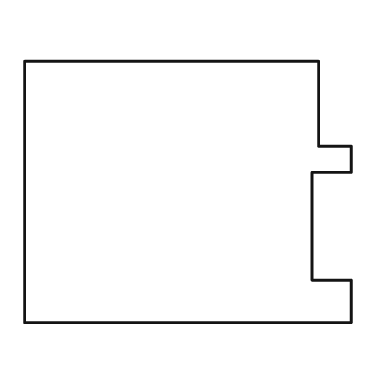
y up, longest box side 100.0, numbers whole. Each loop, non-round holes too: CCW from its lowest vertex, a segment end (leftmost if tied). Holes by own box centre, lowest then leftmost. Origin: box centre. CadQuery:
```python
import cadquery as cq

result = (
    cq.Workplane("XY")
    .moveTo(-50.0, -40.0)
    .lineTo(50.0, -40.0)
    .lineTo(50.0, -27.0)
    .lineTo(38.0, -27.0)
    .lineTo(38.0, 6.0)
    .lineTo(50.0, 6.0)
    .lineTo(50.0, 14.0)
    .lineTo(40.0, 14.0)
    .lineTo(40.0, 40.0)
    .lineTo(-50.0, 40.0)
    .close()
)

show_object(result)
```